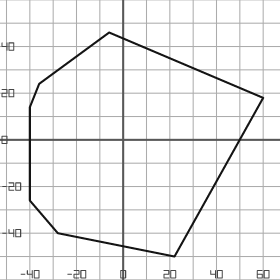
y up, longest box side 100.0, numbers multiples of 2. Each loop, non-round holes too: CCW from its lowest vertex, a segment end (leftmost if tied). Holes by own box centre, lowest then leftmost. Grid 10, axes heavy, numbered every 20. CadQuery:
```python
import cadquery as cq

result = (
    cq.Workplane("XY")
    .moveTo(22.0, -50.0)
    .lineTo(60.0, 18.0)
    .lineTo(-6.0, 46.0)
    .lineTo(-36.0, 24.0)
    .lineTo(-40.0, 14.0)
    .lineTo(-40.0, -26.0)
    .lineTo(-28.0, -40.0)
    .close()
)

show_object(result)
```